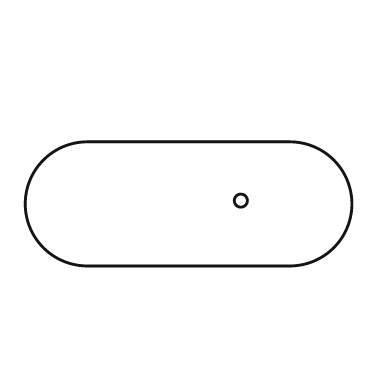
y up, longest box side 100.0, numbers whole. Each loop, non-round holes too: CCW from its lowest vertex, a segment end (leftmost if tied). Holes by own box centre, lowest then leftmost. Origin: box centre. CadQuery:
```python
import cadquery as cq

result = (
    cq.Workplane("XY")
    .moveTo(-31.0, -19.0)
    .lineTo(31.0, -19.0)
    .threePointArc((50.0, 0.0), (31.0, 19.0))
    .lineTo(-31.0, 19.0)
    .threePointArc((-50.0, 0.0), (-31.0, -19.0))
    .close()
    .moveTo(16.0, 1.0)
    .circle(2.0)
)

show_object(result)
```